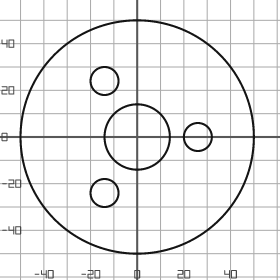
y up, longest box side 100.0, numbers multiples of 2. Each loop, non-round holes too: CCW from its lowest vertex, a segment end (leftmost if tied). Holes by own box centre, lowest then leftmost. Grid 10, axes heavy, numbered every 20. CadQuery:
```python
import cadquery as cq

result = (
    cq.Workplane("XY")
    .moveTo(0.0, 0.0)
    .circle(50.0)
    .moveTo(-14.0, -24.0)
    .circle(6.0)
    .moveTo(0.0, 0.0)
    .circle(14.0)
    .moveTo(26.0, 0.0)
    .circle(6.0)
    .moveTo(-14.0, 24.0)
    .circle(6.0)
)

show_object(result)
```